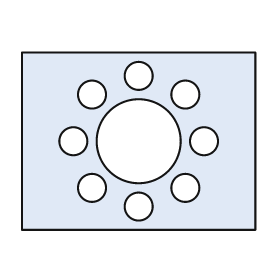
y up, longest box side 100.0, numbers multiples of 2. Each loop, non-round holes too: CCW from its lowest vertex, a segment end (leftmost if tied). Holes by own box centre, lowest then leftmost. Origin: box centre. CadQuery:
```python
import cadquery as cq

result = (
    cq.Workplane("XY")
    .moveTo(-50.0, -38.0)
    .lineTo(50.0, -38.0)
    .lineTo(50.0, 38.0)
    .lineTo(-50.0, 38.0)
    .close()
    .moveTo(0.0, -28.0)
    .circle(6.0)
    .moveTo(-20.0, -20.0)
    .circle(6.0)
    .moveTo(20.0, -20.0)
    .circle(6.0)
    .moveTo(-28.0, 0.0)
    .circle(6.0)
    .moveTo(0.0, 0.0)
    .circle(18.0)
    .moveTo(28.0, 0.0)
    .circle(6.0)
    .moveTo(-20.0, 20.0)
    .circle(6.0)
    .moveTo(20.0, 20.0)
    .circle(6.0)
    .moveTo(0.0, 28.0)
    .circle(6.0)
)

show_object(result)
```